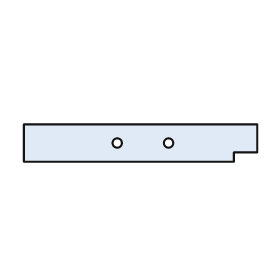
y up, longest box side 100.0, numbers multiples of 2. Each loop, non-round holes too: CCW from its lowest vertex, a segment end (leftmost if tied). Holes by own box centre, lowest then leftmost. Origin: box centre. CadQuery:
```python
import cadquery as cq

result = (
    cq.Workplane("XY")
    .moveTo(-50.0, -8.0)
    .lineTo(40.0, -8.0)
    .lineTo(40.0, -4.0)
    .lineTo(50.0, -4.0)
    .lineTo(50.0, 8.0)
    .lineTo(-50.0, 8.0)
    .close()
    .moveTo(-10.0, 0.0)
    .circle(2.0)
    .moveTo(12.0, 0.0)
    .circle(2.0)
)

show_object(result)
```